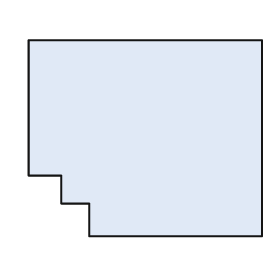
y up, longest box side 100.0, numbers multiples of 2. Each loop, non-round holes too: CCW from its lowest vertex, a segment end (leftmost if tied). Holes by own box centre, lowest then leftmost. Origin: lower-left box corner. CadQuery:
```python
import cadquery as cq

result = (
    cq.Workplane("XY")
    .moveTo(26.0, 0.0)
    .lineTo(100.0, 0.0)
    .lineTo(100.0, 84.0)
    .lineTo(0.0, 84.0)
    .lineTo(0.0, 26.0)
    .lineTo(14.0, 26.0)
    .lineTo(14.0, 14.0)
    .lineTo(26.0, 14.0)
    .close()
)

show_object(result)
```